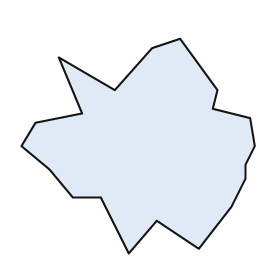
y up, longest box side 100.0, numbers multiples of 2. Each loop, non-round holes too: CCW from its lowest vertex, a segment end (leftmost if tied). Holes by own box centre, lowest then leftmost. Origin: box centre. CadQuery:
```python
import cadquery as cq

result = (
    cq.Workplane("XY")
    .moveTo(-4.0, -46.0)
    .lineTo(8.0, -32.0)
    .lineTo(26.0, -44.0)
    .lineTo(40.0, -26.0)
    .lineTo(46.0, -14.0)
    .lineTo(46.0, -8.0)
    .lineTo(50.0, 0.0)
    .lineTo(48.0, 12.0)
    .lineTo(32.0, 16.0)
    .lineTo(34.0, 24.0)
    .lineTo(18.0, 46.0)
    .lineTo(6.0, 42.0)
    .lineTo(-10.0, 24.0)
    .lineTo(-34.0, 38.0)
    .lineTo(-24.0, 14.0)
    .lineTo(-44.0, 10.0)
    .lineTo(-50.0, 0.0)
    .lineTo(-38.0, -10.0)
    .lineTo(-28.0, -22.0)
    .lineTo(-16.0, -22.0)
    .close()
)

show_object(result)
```